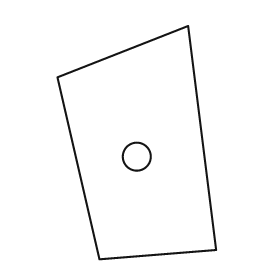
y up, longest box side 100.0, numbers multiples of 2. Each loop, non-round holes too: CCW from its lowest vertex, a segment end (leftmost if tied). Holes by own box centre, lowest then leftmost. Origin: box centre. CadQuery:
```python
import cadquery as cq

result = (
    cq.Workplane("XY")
    .moveTo(-16.0, -50.0)
    .lineTo(34.0, -46.0)
    .lineTo(22.0, 50.0)
    .lineTo(-34.0, 28.0)
    .close()
    .moveTo(0.0, -6.0)
    .circle(6.0)
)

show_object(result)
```